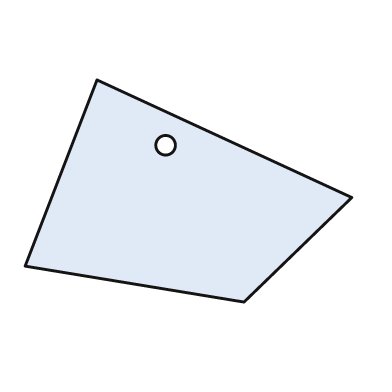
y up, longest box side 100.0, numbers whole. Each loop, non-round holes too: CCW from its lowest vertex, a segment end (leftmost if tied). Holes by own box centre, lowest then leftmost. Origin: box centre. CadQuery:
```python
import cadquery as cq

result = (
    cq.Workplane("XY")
    .moveTo(17.0, -34.0)
    .lineTo(50.0, -2.0)
    .lineTo(-28.0, 34.0)
    .lineTo(-50.0, -23.0)
    .close()
    .moveTo(-7.0, 14.0)
    .circle(3.0)
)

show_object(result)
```